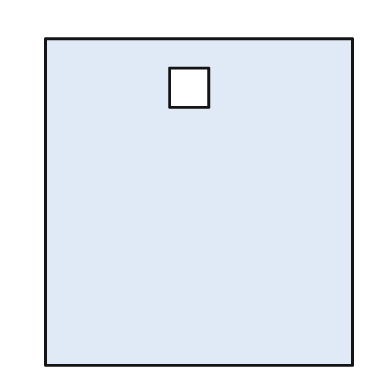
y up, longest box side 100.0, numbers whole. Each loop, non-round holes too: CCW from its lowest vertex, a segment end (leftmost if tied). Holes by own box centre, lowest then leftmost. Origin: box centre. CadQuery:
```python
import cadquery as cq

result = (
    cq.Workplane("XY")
    .moveTo(-47.0, -50.0)
    .lineTo(47.0, -50.0)
    .lineTo(47.0, 50.0)
    .lineTo(-47.0, 50.0)
    .close()
    .moveTo(-9.0, 29.0)
    .lineTo(3.0, 29.0)
    .lineTo(3.0, 41.0)
    .lineTo(-9.0, 41.0)
    .close()
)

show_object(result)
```